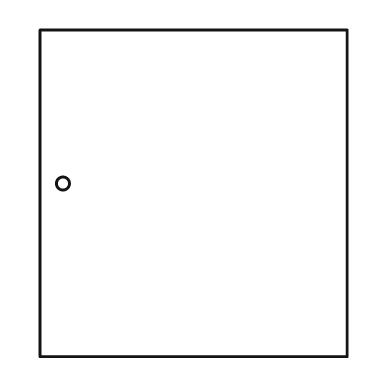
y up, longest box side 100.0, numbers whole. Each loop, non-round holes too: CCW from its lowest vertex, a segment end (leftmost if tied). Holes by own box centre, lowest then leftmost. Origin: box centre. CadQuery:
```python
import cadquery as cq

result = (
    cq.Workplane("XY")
    .moveTo(-47.0, -50.0)
    .lineTo(47.0, -50.0)
    .lineTo(47.0, 50.0)
    .lineTo(-47.0, 50.0)
    .close()
    .moveTo(-40.0, 3.0)
    .circle(2.0)
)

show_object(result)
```